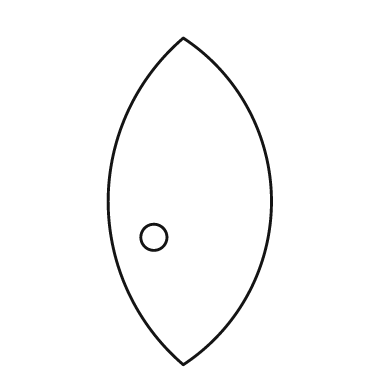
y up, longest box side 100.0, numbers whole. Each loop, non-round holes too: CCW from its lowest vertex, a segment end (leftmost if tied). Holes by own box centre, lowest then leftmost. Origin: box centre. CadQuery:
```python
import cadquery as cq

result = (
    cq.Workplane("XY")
    .moveTo(-2.0, -50.0)
    .threePointArc((25.0, 0.0), (-2.0, 50.0))
    .threePointArc((-25.0, 0.0), (-2.0, -50.0))
    .close()
    .moveTo(-11.0, -11.0)
    .circle(4.0)
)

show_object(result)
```